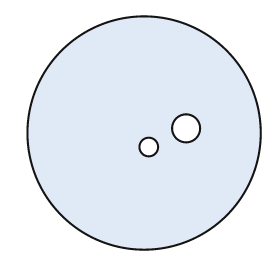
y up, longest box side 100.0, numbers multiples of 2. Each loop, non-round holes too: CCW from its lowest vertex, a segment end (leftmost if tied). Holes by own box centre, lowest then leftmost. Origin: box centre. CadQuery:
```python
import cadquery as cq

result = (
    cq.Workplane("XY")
    .moveTo(0.0, 0.0)
    .circle(50.0)
    .moveTo(2.0, -6.0)
    .circle(4.0)
    .moveTo(18.0, 2.0)
    .circle(6.0)
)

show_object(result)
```